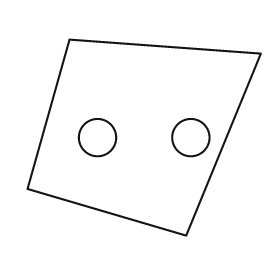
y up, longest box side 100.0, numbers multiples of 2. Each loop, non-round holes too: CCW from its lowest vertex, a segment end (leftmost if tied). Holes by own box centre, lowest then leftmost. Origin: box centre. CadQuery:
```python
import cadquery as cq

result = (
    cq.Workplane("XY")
    .moveTo(18.0, -42.0)
    .lineTo(50.0, 36.0)
    .lineTo(-32.0, 42.0)
    .lineTo(-50.0, -22.0)
    .close()
    .moveTo(-20.0, 0.0)
    .circle(8.0)
    .moveTo(20.0, 0.0)
    .circle(8.0)
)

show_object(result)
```